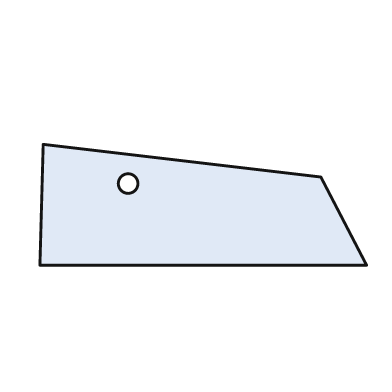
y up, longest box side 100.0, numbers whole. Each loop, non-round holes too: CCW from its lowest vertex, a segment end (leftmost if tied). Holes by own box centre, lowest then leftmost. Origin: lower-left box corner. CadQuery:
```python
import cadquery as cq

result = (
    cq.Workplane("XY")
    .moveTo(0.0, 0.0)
    .lineTo(100.0, 0.0)
    .lineTo(86.0, 27.0)
    .lineTo(1.0, 37.0)
    .close()
    .moveTo(27.0, 25.0)
    .circle(3.0)
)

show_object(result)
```